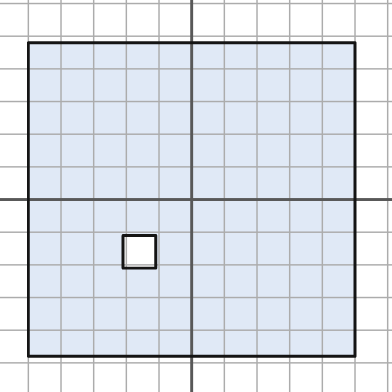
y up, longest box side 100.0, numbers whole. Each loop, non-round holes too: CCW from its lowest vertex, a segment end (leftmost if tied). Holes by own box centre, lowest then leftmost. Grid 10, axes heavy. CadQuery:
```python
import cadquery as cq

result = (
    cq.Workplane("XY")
    .moveTo(-50.0, -48.0)
    .lineTo(50.0, -48.0)
    .lineTo(50.0, 48.0)
    .lineTo(-50.0, 48.0)
    .close()
    .moveTo(-21.0, -21.0)
    .lineTo(-11.0, -21.0)
    .lineTo(-11.0, -11.0)
    .lineTo(-21.0, -11.0)
    .close()
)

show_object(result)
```